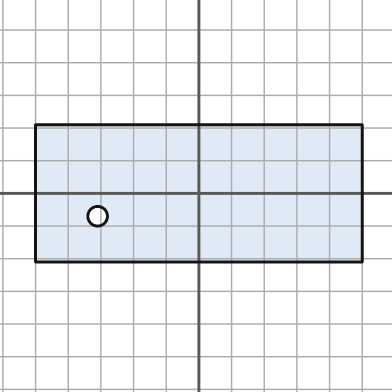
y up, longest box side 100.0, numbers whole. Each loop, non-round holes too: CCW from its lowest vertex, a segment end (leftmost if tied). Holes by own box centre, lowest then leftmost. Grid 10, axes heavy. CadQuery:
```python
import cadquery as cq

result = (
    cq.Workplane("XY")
    .moveTo(-50.0, -21.0)
    .lineTo(50.0, -21.0)
    .lineTo(50.0, 21.0)
    .lineTo(-50.0, 21.0)
    .close()
    .moveTo(-31.0, -7.0)
    .circle(3.0)
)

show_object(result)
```